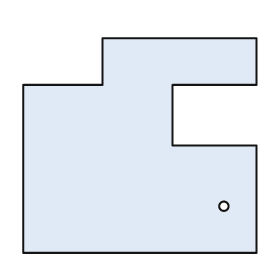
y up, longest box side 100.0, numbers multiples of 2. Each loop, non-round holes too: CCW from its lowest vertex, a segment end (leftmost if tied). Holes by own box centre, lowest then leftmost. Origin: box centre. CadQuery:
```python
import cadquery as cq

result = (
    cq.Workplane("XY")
    .moveTo(-50.0, -46.0)
    .lineTo(50.0, -46.0)
    .lineTo(50.0, 0.0)
    .lineTo(14.0, 0.0)
    .lineTo(14.0, 26.0)
    .lineTo(50.0, 26.0)
    .lineTo(50.0, 46.0)
    .lineTo(-16.0, 46.0)
    .lineTo(-16.0, 26.0)
    .lineTo(-50.0, 26.0)
    .close()
    .moveTo(36.0, -26.0)
    .circle(2.0)
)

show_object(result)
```